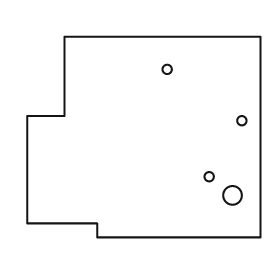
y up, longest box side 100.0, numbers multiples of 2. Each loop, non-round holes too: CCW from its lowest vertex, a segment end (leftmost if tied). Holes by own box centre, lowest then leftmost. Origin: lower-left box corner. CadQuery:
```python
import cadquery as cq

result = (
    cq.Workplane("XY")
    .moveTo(30.0, 0.0)
    .lineTo(100.0, 0.0)
    .lineTo(100.0, 86.0)
    .lineTo(16.0, 86.0)
    .lineTo(16.0, 52.0)
    .lineTo(0.0, 52.0)
    .lineTo(0.0, 6.0)
    .lineTo(30.0, 6.0)
    .close()
    .moveTo(88.0, 18.0)
    .circle(4.0)
    .moveTo(78.0, 26.0)
    .circle(2.0)
    .moveTo(92.0, 50.0)
    .circle(2.0)
    .moveTo(60.0, 72.0)
    .circle(2.0)
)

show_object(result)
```